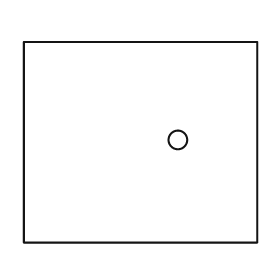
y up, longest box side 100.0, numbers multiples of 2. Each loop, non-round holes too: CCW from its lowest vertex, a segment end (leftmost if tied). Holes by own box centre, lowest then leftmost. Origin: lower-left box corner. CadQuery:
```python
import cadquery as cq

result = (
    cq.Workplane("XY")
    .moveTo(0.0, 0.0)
    .lineTo(100.0, 0.0)
    .lineTo(100.0, 86.0)
    .lineTo(0.0, 86.0)
    .close()
    .moveTo(66.0, 44.0)
    .circle(4.0)
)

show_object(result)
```